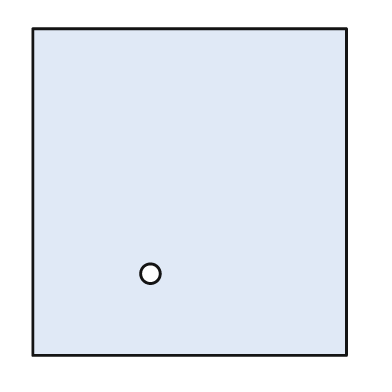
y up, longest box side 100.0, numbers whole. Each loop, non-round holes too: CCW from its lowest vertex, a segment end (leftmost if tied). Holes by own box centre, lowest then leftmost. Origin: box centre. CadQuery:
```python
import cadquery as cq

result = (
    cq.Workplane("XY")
    .moveTo(-48.0, -50.0)
    .lineTo(48.0, -50.0)
    .lineTo(48.0, 50.0)
    .lineTo(-48.0, 50.0)
    .close()
    .moveTo(-12.0, -25.0)
    .circle(3.0)
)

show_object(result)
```